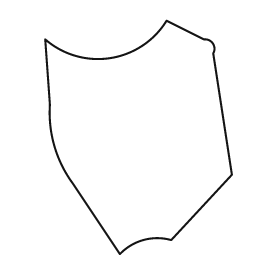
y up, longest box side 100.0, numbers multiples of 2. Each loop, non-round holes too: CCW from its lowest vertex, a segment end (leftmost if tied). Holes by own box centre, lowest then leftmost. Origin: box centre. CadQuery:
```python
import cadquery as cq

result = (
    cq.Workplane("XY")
    .moveTo(-8.0, -50.0)
    .threePointArc((2.0, -44.0), (14.0, -44.0))
    .lineTo(40.0, -16.0)
    .lineTo(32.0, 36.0)
    .threePointArc((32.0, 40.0), (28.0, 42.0))
    .lineTo(12.0, 50.0)
    .threePointArc((-12.0, 34.0), (-40.0, 42.0))
    .lineTo(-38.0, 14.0)
    .threePointArc((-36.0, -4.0), (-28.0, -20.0))
    .close()
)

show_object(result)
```